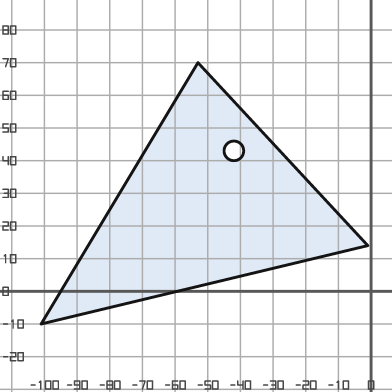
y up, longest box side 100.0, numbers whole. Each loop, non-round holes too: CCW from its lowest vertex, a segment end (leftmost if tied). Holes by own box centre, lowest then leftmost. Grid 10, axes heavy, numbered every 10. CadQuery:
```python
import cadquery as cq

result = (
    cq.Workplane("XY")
    .moveTo(-101.0, -10.0)
    .lineTo(-1.0, 14.0)
    .lineTo(-53.0, 70.0)
    .close()
    .moveTo(-42.0, 43.0)
    .circle(3.0)
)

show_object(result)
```